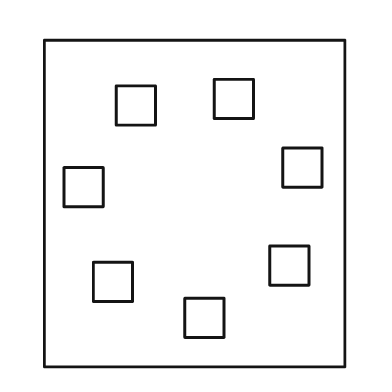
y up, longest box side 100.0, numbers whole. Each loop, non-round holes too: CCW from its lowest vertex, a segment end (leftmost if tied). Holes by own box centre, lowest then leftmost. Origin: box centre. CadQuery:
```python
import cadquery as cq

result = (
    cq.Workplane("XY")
    .moveTo(-46.0, -50.0)
    .lineTo(46.0, -50.0)
    .lineTo(46.0, 50.0)
    .lineTo(-46.0, 50.0)
    .close()
    .moveTo(-3.0, -41.0)
    .lineTo(9.0, -41.0)
    .lineTo(9.0, -29.0)
    .lineTo(-3.0, -29.0)
    .close()
    .moveTo(-31.0, -30.0)
    .lineTo(-19.0, -30.0)
    .lineTo(-19.0, -18.0)
    .lineTo(-31.0, -18.0)
    .close()
    .moveTo(23.0, -25.0)
    .lineTo(35.0, -25.0)
    .lineTo(35.0, -13.0)
    .lineTo(23.0, -13.0)
    .close()
    .moveTo(-40.0, -1.0)
    .lineTo(-28.0, -1.0)
    .lineTo(-28.0, 11.0)
    .lineTo(-40.0, 11.0)
    .close()
    .moveTo(27.0, 5.0)
    .lineTo(39.0, 5.0)
    .lineTo(39.0, 17.0)
    .lineTo(27.0, 17.0)
    .close()
    .moveTo(-24.0, 24.0)
    .lineTo(-12.0, 24.0)
    .lineTo(-12.0, 36.0)
    .lineTo(-24.0, 36.0)
    .close()
    .moveTo(6.0, 26.0)
    .lineTo(18.0, 26.0)
    .lineTo(18.0, 38.0)
    .lineTo(6.0, 38.0)
    .close()
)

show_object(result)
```